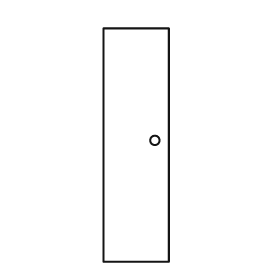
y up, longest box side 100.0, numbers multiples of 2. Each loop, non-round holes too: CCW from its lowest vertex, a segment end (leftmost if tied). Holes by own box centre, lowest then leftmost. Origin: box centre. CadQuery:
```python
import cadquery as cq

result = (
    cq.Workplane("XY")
    .moveTo(-14.0, -50.0)
    .lineTo(14.0, -50.0)
    .lineTo(14.0, 50.0)
    .lineTo(-14.0, 50.0)
    .close()
    .moveTo(8.0, 2.0)
    .circle(2.0)
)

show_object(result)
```